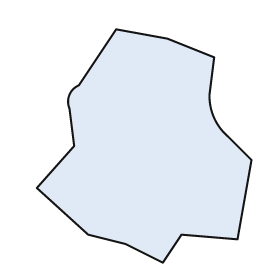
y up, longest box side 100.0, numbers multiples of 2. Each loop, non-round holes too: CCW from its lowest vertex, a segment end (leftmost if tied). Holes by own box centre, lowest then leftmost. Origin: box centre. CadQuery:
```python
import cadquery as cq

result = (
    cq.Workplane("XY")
    .moveTo(8.0, -50.0)
    .lineTo(16.0, -38.0)
    .lineTo(40.0, -40.0)
    .lineTo(46.0, -6.0)
    .lineTo(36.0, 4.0)
    .threePointArc((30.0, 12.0), (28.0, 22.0))
    .lineTo(30.0, 38.0)
    .lineTo(10.0, 46.0)
    .lineTo(-12.0, 50.0)
    .lineTo(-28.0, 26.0)
    .threePointArc((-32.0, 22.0), (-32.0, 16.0))
    .lineTo(-30.0, 0.0)
    .lineTo(-46.0, -18.0)
    .lineTo(-24.0, -38.0)
    .lineTo(-8.0, -42.0)
    .close()
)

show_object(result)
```